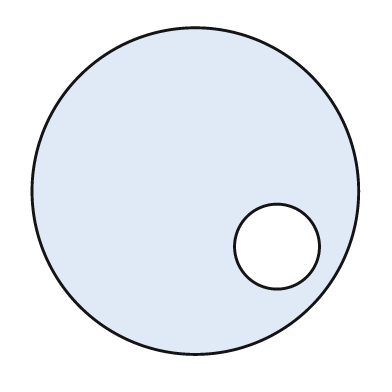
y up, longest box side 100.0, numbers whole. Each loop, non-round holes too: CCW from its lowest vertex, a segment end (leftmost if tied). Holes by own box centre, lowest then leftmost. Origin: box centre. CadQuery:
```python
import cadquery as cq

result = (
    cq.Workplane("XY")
    .moveTo(0.0, 0.0)
    .circle(50.0)
    .moveTo(25.0, -17.0)
    .circle(13.0)
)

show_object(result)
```